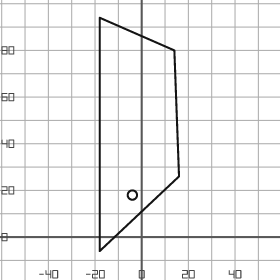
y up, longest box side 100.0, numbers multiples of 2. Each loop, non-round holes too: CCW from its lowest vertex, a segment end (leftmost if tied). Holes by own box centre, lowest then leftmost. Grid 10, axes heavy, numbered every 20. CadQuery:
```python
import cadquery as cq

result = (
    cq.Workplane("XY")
    .moveTo(-18.0, -6.0)
    .lineTo(16.0, 26.0)
    .lineTo(14.0, 80.0)
    .lineTo(-18.0, 94.0)
    .close()
    .moveTo(-4.0, 18.0)
    .circle(2.0)
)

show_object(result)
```